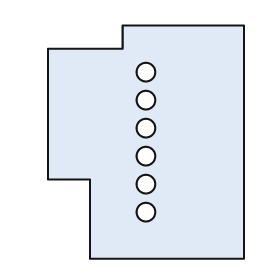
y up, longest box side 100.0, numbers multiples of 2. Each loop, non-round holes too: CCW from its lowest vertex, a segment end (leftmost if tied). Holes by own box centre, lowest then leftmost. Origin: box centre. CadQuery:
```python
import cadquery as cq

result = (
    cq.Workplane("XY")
    .moveTo(-24.0, -50.0)
    .lineTo(42.0, -50.0)
    .lineTo(42.0, 50.0)
    .lineTo(-10.0, 50.0)
    .lineTo(-10.0, 40.0)
    .lineTo(-42.0, 40.0)
    .lineTo(-42.0, -16.0)
    .lineTo(-24.0, -16.0)
    .close()
    .moveTo(0.0, -30.0)
    .circle(4.0)
    .moveTo(0.0, -18.0)
    .circle(4.0)
    .moveTo(0.0, -6.0)
    .circle(4.0)
    .moveTo(0.0, 6.0)
    .circle(4.0)
    .moveTo(0.0, 18.0)
    .circle(4.0)
    .moveTo(0.0, 30.0)
    .circle(4.0)
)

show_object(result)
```